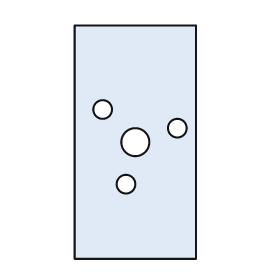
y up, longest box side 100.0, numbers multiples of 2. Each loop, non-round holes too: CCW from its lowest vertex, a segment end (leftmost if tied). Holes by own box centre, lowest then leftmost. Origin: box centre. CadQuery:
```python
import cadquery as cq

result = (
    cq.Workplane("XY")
    .moveTo(-26.0, -50.0)
    .lineTo(26.0, -50.0)
    .lineTo(26.0, 50.0)
    .lineTo(-26.0, 50.0)
    .close()
    .moveTo(-4.0, -18.0)
    .circle(4.0)
    .moveTo(0.0, 0.0)
    .circle(6.0)
    .moveTo(18.0, 6.0)
    .circle(4.0)
    .moveTo(-14.0, 14.0)
    .circle(4.0)
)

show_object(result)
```